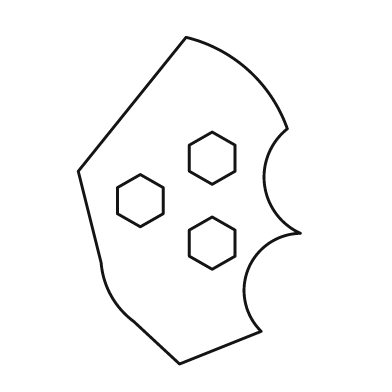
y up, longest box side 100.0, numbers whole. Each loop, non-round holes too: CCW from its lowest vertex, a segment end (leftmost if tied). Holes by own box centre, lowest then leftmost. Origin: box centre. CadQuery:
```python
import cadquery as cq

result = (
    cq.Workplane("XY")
    .moveTo(-3.0, -50.0)
    .lineTo(22.0, -40.0)
    .threePointArc((18.0, -21.0), (34.0, -10.0))
    .threePointArc((23.0, 5.0), (30.0, 22.0))
    .threePointArc((18.0, 40.0), (-1.0, 50.0))
    .lineTo(-34.0, 9.0)
    .lineTo(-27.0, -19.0)
    .threePointArc((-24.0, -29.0), (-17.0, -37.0))
    .close()
    .moveTo(7.0, -21.0)
    .lineTo(14.0, -17.0)
    .lineTo(14.0, -9.0)
    .lineTo(7.0, -5.0)
    .lineTo(0.0, -9.0)
    .lineTo(0.0, -17.0)
    .close()
    .moveTo(-15.0, -8.0)
    .lineTo(-8.0, -4.0)
    .lineTo(-8.0, 4.0)
    .lineTo(-15.0, 8.0)
    .lineTo(-22.0, 4.0)
    .lineTo(-22.0, -4.0)
    .close()
    .moveTo(7.0, 5.0)
    .lineTo(14.0, 9.0)
    .lineTo(14.0, 17.0)
    .lineTo(7.0, 21.0)
    .lineTo(0.0, 17.0)
    .lineTo(0.0, 9.0)
    .close()
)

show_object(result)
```